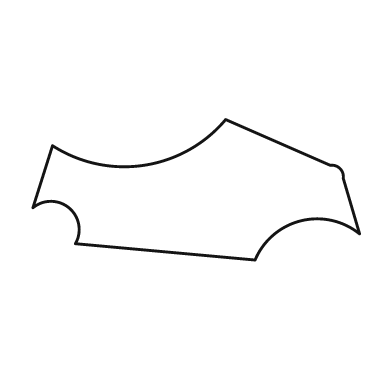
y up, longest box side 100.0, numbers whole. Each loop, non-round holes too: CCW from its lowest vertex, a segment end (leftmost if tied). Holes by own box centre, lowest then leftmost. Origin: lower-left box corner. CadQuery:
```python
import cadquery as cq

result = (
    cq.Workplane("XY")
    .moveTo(68.0, 0.0)
    .threePointArc((82.0, 12.0), (100.0, 8.0))
    .lineTo(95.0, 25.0)
    .threePointArc((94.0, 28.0), (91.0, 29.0))
    .lineTo(59.0, 43.0)
    .threePointArc((34.0, 29.0), (6.0, 35.0))
    .lineTo(0.0, 16.0)
    .threePointArc((11.0, 16.0), (13.0, 5.0))
    .close()
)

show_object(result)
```